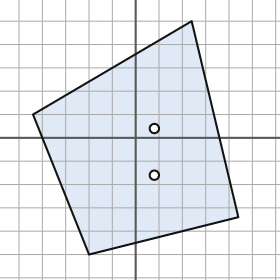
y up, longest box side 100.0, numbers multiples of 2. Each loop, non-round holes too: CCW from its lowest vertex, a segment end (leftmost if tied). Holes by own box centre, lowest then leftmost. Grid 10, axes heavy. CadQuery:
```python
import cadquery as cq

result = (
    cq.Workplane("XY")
    .moveTo(-20.0, -50.0)
    .lineTo(44.0, -34.0)
    .lineTo(24.0, 50.0)
    .lineTo(-44.0, 10.0)
    .close()
    .moveTo(8.0, -16.0)
    .circle(2.0)
    .moveTo(8.0, 4.0)
    .circle(2.0)
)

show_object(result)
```